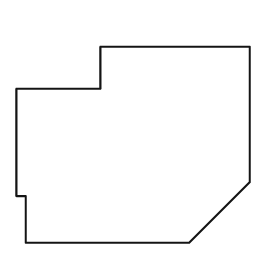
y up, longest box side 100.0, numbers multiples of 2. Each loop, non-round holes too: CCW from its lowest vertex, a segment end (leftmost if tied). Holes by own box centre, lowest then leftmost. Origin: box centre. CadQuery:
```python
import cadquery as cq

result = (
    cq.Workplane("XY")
    .moveTo(-46.0, -42.0)
    .lineTo(24.0, -42.0)
    .lineTo(50.0, -16.0)
    .lineTo(50.0, 42.0)
    .lineTo(-14.0, 42.0)
    .lineTo(-14.0, 24.0)
    .lineTo(-50.0, 24.0)
    .lineTo(-50.0, -22.0)
    .lineTo(-46.0, -22.0)
    .close()
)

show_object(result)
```